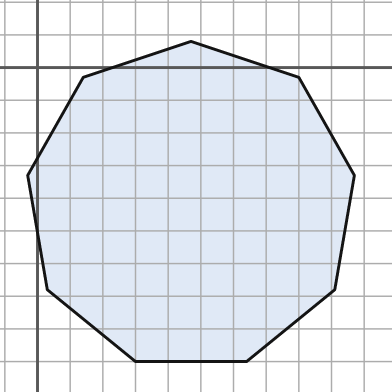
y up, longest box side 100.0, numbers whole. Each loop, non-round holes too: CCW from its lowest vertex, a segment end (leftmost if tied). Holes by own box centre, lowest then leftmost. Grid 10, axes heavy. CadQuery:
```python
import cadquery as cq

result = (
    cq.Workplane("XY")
    .moveTo(30.0, -90.0)
    .lineTo(64.0, -90.0)
    .lineTo(91.0, -68.0)
    .lineTo(97.0, -33.0)
    .lineTo(80.0, -3.0)
    .lineTo(47.0, 8.0)
    .lineTo(14.0, -3.0)
    .lineTo(-3.0, -33.0)
    .lineTo(3.0, -68.0)
    .close()
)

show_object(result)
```